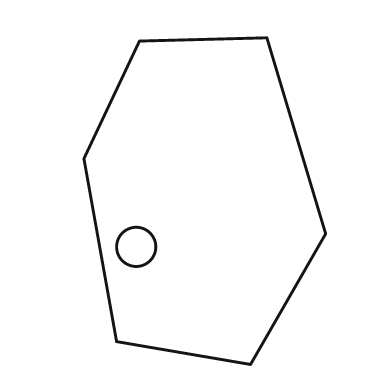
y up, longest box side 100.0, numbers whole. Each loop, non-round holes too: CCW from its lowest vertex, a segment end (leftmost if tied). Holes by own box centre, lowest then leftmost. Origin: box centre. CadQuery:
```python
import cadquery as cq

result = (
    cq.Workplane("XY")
    .moveTo(14.0, -50.0)
    .lineTo(37.0, -10.0)
    .lineTo(19.0, 50.0)
    .lineTo(-20.0, 49.0)
    .lineTo(-37.0, 13.0)
    .lineTo(-27.0, -43.0)
    .close()
    .moveTo(-21.0, -14.0)
    .circle(6.0)
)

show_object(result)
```